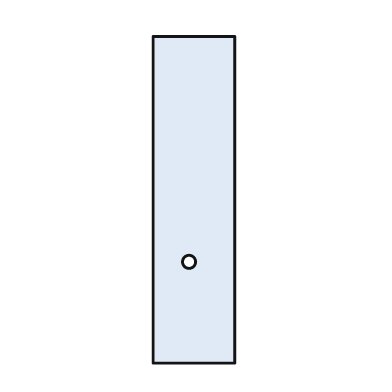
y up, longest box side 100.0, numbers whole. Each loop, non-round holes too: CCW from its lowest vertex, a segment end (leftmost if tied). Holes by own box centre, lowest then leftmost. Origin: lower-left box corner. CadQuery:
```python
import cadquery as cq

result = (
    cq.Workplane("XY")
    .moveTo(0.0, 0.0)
    .lineTo(25.0, 0.0)
    .lineTo(25.0, 100.0)
    .lineTo(0.0, 100.0)
    .close()
    .moveTo(11.0, 31.0)
    .circle(2.0)
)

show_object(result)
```